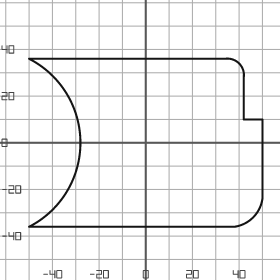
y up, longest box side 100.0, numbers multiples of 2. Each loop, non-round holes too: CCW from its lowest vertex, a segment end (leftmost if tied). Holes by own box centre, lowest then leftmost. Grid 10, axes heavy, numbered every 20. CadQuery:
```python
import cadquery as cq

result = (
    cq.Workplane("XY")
    .moveTo(-50.0, -36.0)
    .lineTo(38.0, -36.0)
    .threePointArc((46.0, -32.0), (50.0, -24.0))
    .lineTo(50.0, 10.0)
    .lineTo(42.0, 10.0)
    .lineTo(42.0, 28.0)
    .threePointArc((40.0, 34.0), (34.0, 36.0))
    .lineTo(-50.0, 36.0)
    .threePointArc((-28.0, 0.0), (-50.0, -36.0))
    .close()
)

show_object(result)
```